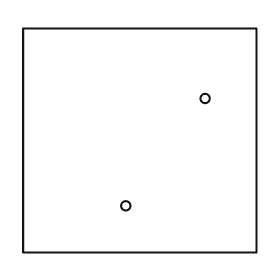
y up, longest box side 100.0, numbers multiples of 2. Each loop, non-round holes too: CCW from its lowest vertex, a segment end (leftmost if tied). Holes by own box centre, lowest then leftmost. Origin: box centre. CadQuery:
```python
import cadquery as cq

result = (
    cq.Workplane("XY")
    .moveTo(-50.0, -48.0)
    .lineTo(50.0, -48.0)
    .lineTo(50.0, 48.0)
    .lineTo(-50.0, 48.0)
    .close()
    .moveTo(-6.0, -28.0)
    .circle(2.0)
    .moveTo(28.0, 18.0)
    .circle(2.0)
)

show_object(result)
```